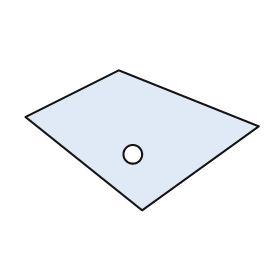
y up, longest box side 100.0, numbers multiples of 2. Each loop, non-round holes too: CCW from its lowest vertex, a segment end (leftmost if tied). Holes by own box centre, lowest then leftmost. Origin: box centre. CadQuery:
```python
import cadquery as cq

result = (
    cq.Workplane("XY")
    .moveTo(0.0, -30.0)
    .lineTo(50.0, 6.0)
    .lineTo(-10.0, 30.0)
    .lineTo(-50.0, 10.0)
    .close()
    .moveTo(-4.0, -6.0)
    .circle(4.0)
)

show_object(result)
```